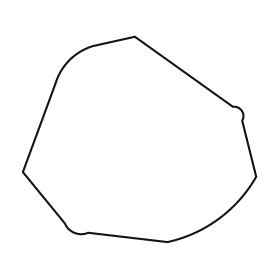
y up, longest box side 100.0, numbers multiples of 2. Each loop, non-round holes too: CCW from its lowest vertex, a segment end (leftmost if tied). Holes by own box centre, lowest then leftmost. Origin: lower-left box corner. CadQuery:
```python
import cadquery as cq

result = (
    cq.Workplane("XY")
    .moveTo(62.0, 0.0)
    .threePointArc((84.0, 10.0), (100.0, 28.0))
    .lineTo(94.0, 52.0)
    .threePointArc((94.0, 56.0), (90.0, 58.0))
    .lineTo(48.0, 88.0)
    .lineTo(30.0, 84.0)
    .threePointArc((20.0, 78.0), (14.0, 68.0))
    .lineTo(0.0, 30.0)
    .lineTo(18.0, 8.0)
    .threePointArc((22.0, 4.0), (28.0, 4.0))
    .close()
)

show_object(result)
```